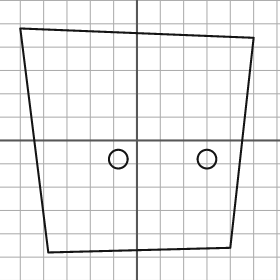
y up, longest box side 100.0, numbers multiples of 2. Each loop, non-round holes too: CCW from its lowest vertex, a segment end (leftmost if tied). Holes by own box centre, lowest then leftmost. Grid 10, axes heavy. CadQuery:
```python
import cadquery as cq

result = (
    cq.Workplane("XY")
    .moveTo(-38.0, -48.0)
    .lineTo(40.0, -46.0)
    .lineTo(50.0, 44.0)
    .lineTo(-50.0, 48.0)
    .close()
    .moveTo(-8.0, -8.0)
    .circle(4.0)
    .moveTo(30.0, -8.0)
    .circle(4.0)
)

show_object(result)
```